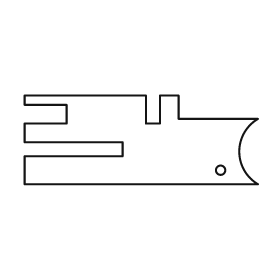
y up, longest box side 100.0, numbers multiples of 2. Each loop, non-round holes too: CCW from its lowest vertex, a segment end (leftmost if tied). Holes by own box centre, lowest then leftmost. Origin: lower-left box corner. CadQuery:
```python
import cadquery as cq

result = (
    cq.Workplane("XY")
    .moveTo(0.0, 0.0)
    .lineTo(100.0, 0.0)
    .threePointArc((92.0, 14.0), (100.0, 28.0))
    .lineTo(66.0, 28.0)
    .lineTo(66.0, 38.0)
    .lineTo(58.0, 38.0)
    .lineTo(58.0, 26.0)
    .lineTo(52.0, 26.0)
    .lineTo(52.0, 38.0)
    .lineTo(0.0, 38.0)
    .lineTo(0.0, 34.0)
    .lineTo(18.0, 34.0)
    .lineTo(18.0, 26.0)
    .lineTo(0.0, 26.0)
    .lineTo(0.0, 18.0)
    .lineTo(42.0, 18.0)
    .lineTo(42.0, 12.0)
    .lineTo(0.0, 12.0)
    .close()
    .moveTo(84.0, 6.0)
    .circle(2.0)
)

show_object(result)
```